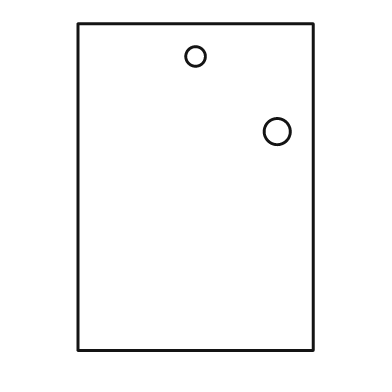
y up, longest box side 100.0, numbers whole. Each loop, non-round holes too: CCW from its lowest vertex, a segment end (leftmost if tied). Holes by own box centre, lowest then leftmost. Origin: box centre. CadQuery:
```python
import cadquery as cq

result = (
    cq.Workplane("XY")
    .moveTo(-36.0, -50.0)
    .lineTo(36.0, -50.0)
    .lineTo(36.0, 50.0)
    .lineTo(-36.0, 50.0)
    .close()
    .moveTo(25.0, 17.0)
    .circle(4.0)
    .moveTo(0.0, 40.0)
    .circle(3.0)
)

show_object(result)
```